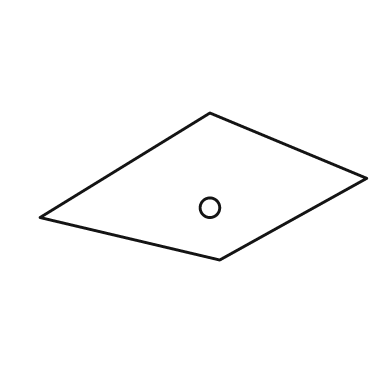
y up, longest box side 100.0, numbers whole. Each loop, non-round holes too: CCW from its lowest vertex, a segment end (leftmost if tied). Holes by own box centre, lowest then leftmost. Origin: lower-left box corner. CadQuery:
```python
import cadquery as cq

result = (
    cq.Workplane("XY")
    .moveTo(55.0, 0.0)
    .lineTo(100.0, 25.0)
    .lineTo(52.0, 45.0)
    .lineTo(0.0, 13.0)
    .close()
    .moveTo(52.0, 16.0)
    .circle(3.0)
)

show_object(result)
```